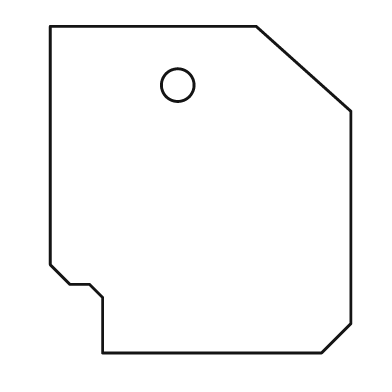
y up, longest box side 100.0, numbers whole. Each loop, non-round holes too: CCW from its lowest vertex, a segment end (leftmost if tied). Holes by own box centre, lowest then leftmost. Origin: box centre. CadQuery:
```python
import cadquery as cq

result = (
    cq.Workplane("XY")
    .moveTo(-30.0, -50.0)
    .lineTo(37.0, -50.0)
    .lineTo(46.0, -41.0)
    .lineTo(46.0, 24.0)
    .lineTo(17.0, 50.0)
    .lineTo(-46.0, 50.0)
    .lineTo(-46.0, -23.0)
    .lineTo(-40.0, -29.0)
    .lineTo(-34.0, -29.0)
    .lineTo(-30.0, -33.0)
    .close()
    .moveTo(-7.0, 32.0)
    .circle(5.0)
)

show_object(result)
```